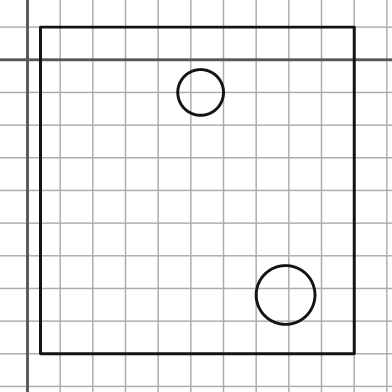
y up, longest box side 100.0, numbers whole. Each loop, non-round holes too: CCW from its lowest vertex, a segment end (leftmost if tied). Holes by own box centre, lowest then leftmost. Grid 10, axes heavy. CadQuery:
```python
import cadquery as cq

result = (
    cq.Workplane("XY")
    .moveTo(4.0, -90.0)
    .lineTo(100.0, -90.0)
    .lineTo(100.0, 10.0)
    .lineTo(4.0, 10.0)
    .close()
    .moveTo(79.0, -72.0)
    .circle(9.0)
    .moveTo(53.0, -10.0)
    .circle(7.0)
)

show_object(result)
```